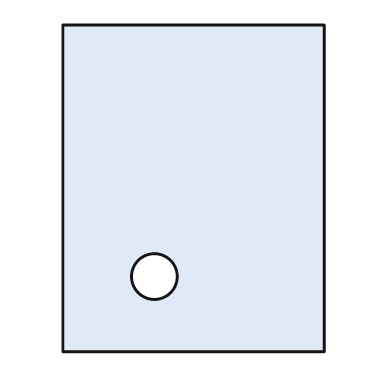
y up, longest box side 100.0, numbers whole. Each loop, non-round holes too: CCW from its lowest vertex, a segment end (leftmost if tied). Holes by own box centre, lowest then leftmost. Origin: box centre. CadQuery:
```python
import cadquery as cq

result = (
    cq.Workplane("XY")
    .moveTo(-40.0, -50.0)
    .lineTo(40.0, -50.0)
    .lineTo(40.0, 50.0)
    .lineTo(-40.0, 50.0)
    .close()
    .moveTo(-12.0, -27.0)
    .circle(7.0)
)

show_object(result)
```